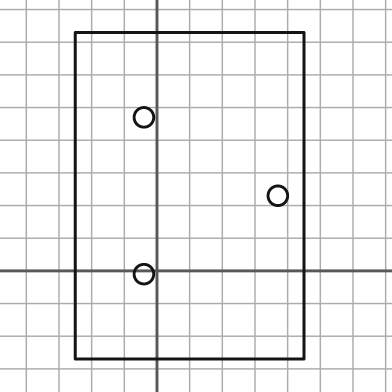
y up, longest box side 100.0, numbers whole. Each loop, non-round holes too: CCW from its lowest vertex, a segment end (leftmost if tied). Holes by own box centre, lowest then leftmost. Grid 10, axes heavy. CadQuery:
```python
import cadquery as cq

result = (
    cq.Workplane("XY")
    .moveTo(-25.0, -27.0)
    .lineTo(45.0, -27.0)
    .lineTo(45.0, 73.0)
    .lineTo(-25.0, 73.0)
    .close()
    .moveTo(-4.0, -1.0)
    .circle(3.0)
    .moveTo(37.0, 23.0)
    .circle(3.0)
    .moveTo(-4.0, 47.0)
    .circle(3.0)
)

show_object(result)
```